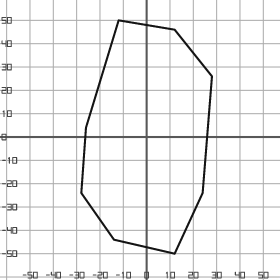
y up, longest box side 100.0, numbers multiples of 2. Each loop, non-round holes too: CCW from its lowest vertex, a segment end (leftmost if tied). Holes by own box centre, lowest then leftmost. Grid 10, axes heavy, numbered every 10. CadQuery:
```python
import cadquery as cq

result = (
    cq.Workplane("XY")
    .moveTo(12.0, -50.0)
    .lineTo(24.0, -24.0)
    .lineTo(28.0, 26.0)
    .lineTo(12.0, 46.0)
    .lineTo(-12.0, 50.0)
    .lineTo(-26.0, 4.0)
    .lineTo(-28.0, -24.0)
    .lineTo(-14.0, -44.0)
    .close()
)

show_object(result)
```